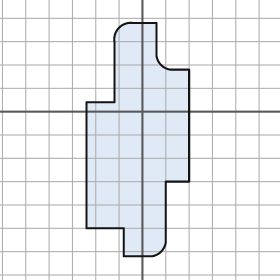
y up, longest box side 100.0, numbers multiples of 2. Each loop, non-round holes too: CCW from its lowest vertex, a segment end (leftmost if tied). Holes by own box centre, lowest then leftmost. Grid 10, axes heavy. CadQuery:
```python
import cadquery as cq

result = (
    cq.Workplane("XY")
    .moveTo(-8.0, -62.0)
    .lineTo(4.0, -62.0)
    .threePointArc((8.0, -60.0), (10.0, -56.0))
    .lineTo(10.0, -30.0)
    .lineTo(20.0, -30.0)
    .lineTo(20.0, 18.0)
    .lineTo(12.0, 18.0)
    .threePointArc((8.0, 20.0), (6.0, 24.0))
    .lineTo(6.0, 38.0)
    .lineTo(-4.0, 38.0)
    .threePointArc((-10.0, 36.0), (-12.0, 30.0))
    .lineTo(-12.0, 4.0)
    .lineTo(-24.0, 4.0)
    .lineTo(-24.0, -50.0)
    .lineTo(-8.0, -50.0)
    .close()
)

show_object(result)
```